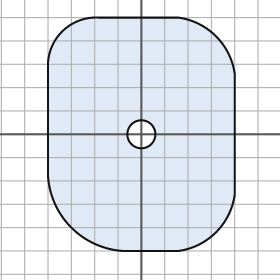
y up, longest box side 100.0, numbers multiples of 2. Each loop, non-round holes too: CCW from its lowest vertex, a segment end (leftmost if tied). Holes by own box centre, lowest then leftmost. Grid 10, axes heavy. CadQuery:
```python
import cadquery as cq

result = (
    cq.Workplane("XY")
    .moveTo(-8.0, -50.0)
    .lineTo(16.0, -50.0)
    .threePointArc((32.0, -42.0), (40.0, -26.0))
    .lineTo(40.0, 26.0)
    .threePointArc((32.0, 42.0), (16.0, 50.0))
    .lineTo(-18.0, 50.0)
    .threePointArc((-34.0, 44.0), (-40.0, 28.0))
    .lineTo(-40.0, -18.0)
    .threePointArc((-30.0, -40.0), (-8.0, -50.0))
    .close()
    .moveTo(0.0, 0.0)
    .circle(6.0)
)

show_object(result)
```